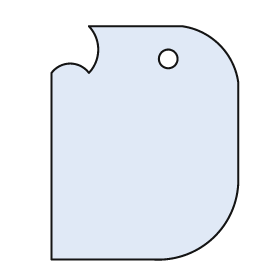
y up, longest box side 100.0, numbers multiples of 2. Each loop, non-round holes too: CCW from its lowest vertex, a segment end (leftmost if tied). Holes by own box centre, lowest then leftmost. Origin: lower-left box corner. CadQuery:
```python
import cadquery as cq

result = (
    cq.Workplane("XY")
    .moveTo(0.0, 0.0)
    .lineTo(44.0, 0.0)
    .threePointArc((70.0, 10.0), (80.0, 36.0))
    .lineTo(80.0, 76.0)
    .threePointArc((72.0, 92.0), (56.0, 100.0))
    .lineTo(16.0, 100.0)
    .threePointArc((20.0, 90.0), (16.0, 80.0))
    .threePointArc((8.0, 84.0), (0.0, 80.0))
    .close()
    .moveTo(50.0, 86.0)
    .circle(4.0)
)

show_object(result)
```